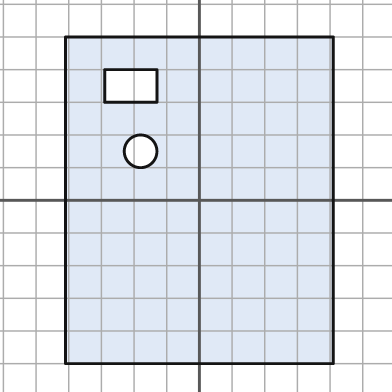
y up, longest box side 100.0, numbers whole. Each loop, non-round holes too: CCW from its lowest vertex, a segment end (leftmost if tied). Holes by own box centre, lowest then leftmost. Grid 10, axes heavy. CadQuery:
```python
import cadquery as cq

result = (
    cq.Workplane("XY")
    .moveTo(-41.0, -50.0)
    .lineTo(41.0, -50.0)
    .lineTo(41.0, 50.0)
    .lineTo(-41.0, 50.0)
    .close()
    .moveTo(-18.0, 15.0)
    .circle(5.0)
    .moveTo(-29.0, 30.0)
    .lineTo(-13.0, 30.0)
    .lineTo(-13.0, 40.0)
    .lineTo(-29.0, 40.0)
    .close()
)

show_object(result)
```